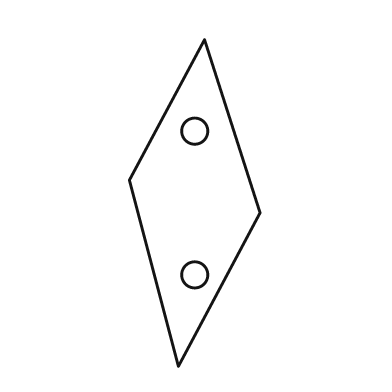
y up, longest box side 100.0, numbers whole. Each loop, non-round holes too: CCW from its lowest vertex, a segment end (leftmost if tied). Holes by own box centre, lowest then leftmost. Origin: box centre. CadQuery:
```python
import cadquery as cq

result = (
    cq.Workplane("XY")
    .moveTo(-5.0, -50.0)
    .lineTo(20.0, -3.0)
    .lineTo(3.0, 50.0)
    .lineTo(-20.0, 7.0)
    .close()
    .moveTo(0.0, -22.0)
    .circle(4.0)
    .moveTo(0.0, 22.0)
    .circle(4.0)
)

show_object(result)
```